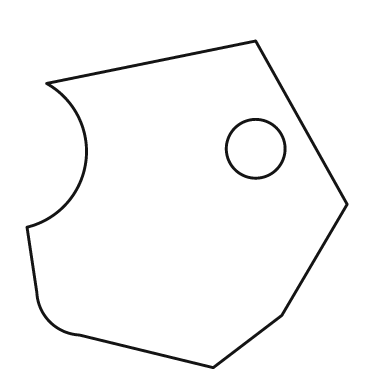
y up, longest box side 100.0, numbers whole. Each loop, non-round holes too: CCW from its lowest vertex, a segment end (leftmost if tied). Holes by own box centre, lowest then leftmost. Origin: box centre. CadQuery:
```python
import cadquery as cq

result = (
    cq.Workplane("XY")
    .moveTo(8.0, -50.0)
    .lineTo(29.0, -34.0)
    .lineTo(49.0, 0.0)
    .lineTo(21.0, 50.0)
    .lineTo(-43.0, 37.0)
    .threePointArc((-31.0, 13.0), (-49.0, -7.0))
    .lineTo(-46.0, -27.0)
    .threePointArc((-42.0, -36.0), (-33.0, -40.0))
    .close()
    .moveTo(21.0, 17.0)
    .circle(9.0)
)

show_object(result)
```